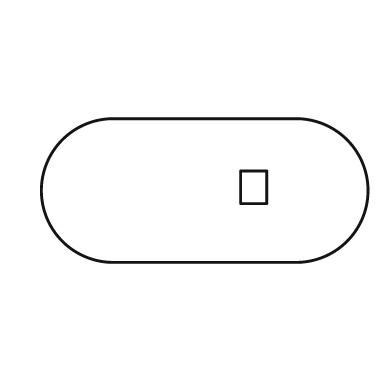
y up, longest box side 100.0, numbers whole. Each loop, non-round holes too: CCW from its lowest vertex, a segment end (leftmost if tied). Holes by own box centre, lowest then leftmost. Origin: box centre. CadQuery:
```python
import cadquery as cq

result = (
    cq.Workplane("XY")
    .moveTo(-28.0, -22.0)
    .lineTo(28.0, -22.0)
    .threePointArc((50.0, 0.0), (28.0, 22.0))
    .lineTo(-28.0, 22.0)
    .threePointArc((-50.0, 0.0), (-28.0, -22.0))
    .close()
    .moveTo(11.0, -4.0)
    .lineTo(19.0, -4.0)
    .lineTo(19.0, 6.0)
    .lineTo(11.0, 6.0)
    .close()
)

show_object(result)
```